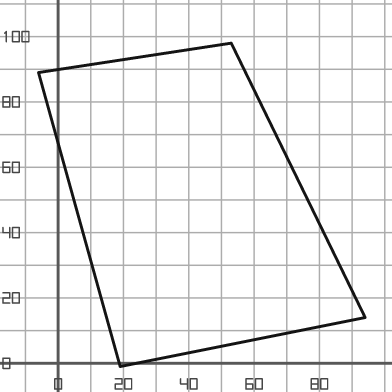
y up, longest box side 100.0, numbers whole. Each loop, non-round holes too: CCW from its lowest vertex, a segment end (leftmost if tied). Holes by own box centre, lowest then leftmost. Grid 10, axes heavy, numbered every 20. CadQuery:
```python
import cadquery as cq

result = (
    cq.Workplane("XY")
    .moveTo(19.0, -1.0)
    .lineTo(94.0, 14.0)
    .lineTo(53.0, 98.0)
    .lineTo(-6.0, 89.0)
    .close()
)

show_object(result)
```